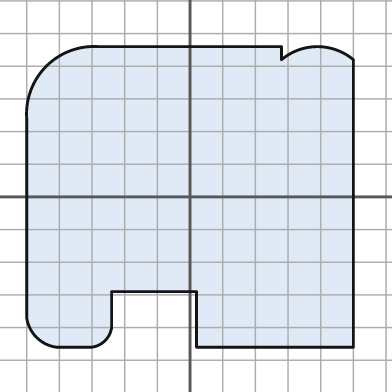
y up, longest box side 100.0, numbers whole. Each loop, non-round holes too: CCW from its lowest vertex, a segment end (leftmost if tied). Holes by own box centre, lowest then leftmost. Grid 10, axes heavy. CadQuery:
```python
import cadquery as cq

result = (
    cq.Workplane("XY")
    .moveTo(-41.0, -46.0)
    .lineTo(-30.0, -46.0)
    .threePointArc((-26.0, -44.0), (-24.0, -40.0))
    .lineTo(-24.0, -29.0)
    .lineTo(2.0, -29.0)
    .lineTo(2.0, -46.0)
    .lineTo(50.0, -46.0)
    .lineTo(50.0, 42.0)
    .threePointArc((39.0, 46.0), (28.0, 42.0))
    .lineTo(28.0, 46.0)
    .lineTo(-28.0, 46.0)
    .threePointArc((-44.0, 40.0), (-50.0, 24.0))
    .lineTo(-50.0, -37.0)
    .threePointArc((-47.0, -43.0), (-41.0, -46.0))
    .close()
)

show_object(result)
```